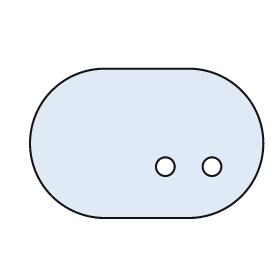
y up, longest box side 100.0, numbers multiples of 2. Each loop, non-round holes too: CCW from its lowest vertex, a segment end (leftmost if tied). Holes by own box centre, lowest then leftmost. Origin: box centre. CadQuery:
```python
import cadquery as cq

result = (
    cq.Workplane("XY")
    .moveTo(-18.0, -32.0)
    .lineTo(18.0, -32.0)
    .threePointArc((50.0, 0.0), (18.0, 32.0))
    .lineTo(-18.0, 32.0)
    .threePointArc((-50.0, 0.0), (-18.0, -32.0))
    .close()
    .moveTo(8.0, -10.0)
    .circle(4.0)
    .moveTo(28.0, -10.0)
    .circle(4.0)
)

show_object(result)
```